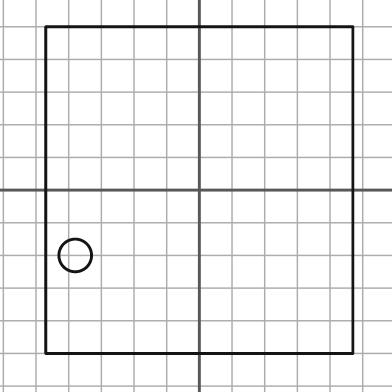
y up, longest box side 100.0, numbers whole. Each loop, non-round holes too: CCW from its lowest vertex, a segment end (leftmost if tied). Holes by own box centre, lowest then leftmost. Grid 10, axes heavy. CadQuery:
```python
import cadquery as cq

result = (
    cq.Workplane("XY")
    .moveTo(-47.0, -50.0)
    .lineTo(47.0, -50.0)
    .lineTo(47.0, 50.0)
    .lineTo(-47.0, 50.0)
    .close()
    .moveTo(-38.0, -20.0)
    .circle(5.0)
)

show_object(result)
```